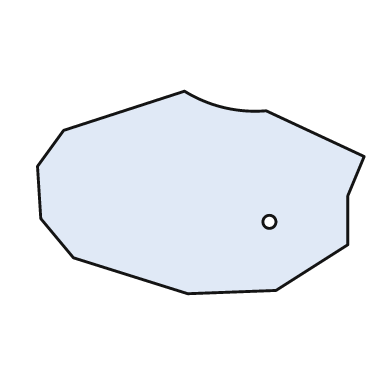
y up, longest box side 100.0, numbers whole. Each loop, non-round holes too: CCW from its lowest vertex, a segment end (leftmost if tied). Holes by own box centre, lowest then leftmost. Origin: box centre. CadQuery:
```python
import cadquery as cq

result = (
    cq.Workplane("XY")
    .moveTo(-4.0, -31.0)
    .lineTo(23.0, -30.0)
    .lineTo(45.0, -16.0)
    .lineTo(45.0, -1.0)
    .lineTo(50.0, 11.0)
    .lineTo(20.0, 25.0)
    .threePointArc((7.0, 26.0), (-5.0, 31.0))
    .lineTo(-42.0, 19.0)
    .lineTo(-50.0, 8.0)
    .lineTo(-49.0, -8.0)
    .lineTo(-39.0, -20.0)
    .close()
    .moveTo(21.0, -9.0)
    .circle(2.0)
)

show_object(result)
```